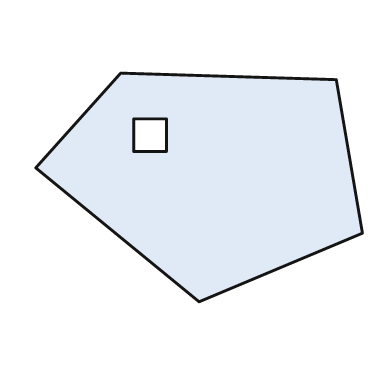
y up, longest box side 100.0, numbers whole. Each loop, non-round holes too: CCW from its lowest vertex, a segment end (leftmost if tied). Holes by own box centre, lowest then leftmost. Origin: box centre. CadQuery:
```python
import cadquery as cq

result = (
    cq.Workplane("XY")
    .moveTo(0.0, -35.0)
    .lineTo(50.0, -14.0)
    .lineTo(42.0, 33.0)
    .lineTo(-24.0, 35.0)
    .lineTo(-50.0, 6.0)
    .close()
    .moveTo(-20.0, 11.0)
    .lineTo(-10.0, 11.0)
    .lineTo(-10.0, 21.0)
    .lineTo(-20.0, 21.0)
    .close()
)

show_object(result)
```